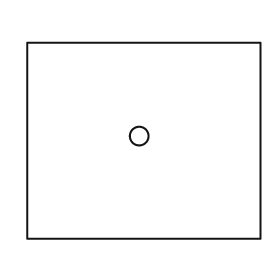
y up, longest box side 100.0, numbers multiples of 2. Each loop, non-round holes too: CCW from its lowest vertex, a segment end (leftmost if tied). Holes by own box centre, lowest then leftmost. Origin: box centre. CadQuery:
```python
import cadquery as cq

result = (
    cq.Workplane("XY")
    .moveTo(-50.0, -42.0)
    .lineTo(50.0, -42.0)
    .lineTo(50.0, 42.0)
    .lineTo(-50.0, 42.0)
    .close()
    .moveTo(-2.0, 2.0)
    .circle(4.0)
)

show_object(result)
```